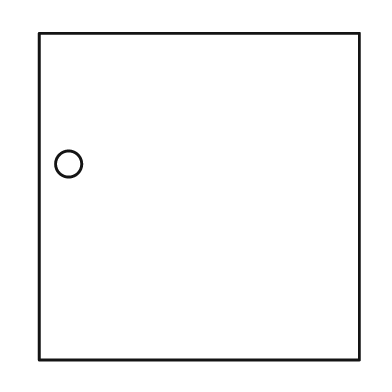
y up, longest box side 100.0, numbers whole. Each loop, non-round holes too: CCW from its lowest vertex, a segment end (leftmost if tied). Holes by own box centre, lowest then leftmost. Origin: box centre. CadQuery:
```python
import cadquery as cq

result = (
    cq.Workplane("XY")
    .moveTo(-49.0, -50.0)
    .lineTo(49.0, -50.0)
    .lineTo(49.0, 50.0)
    .lineTo(-49.0, 50.0)
    .close()
    .moveTo(-40.0, 10.0)
    .circle(4.0)
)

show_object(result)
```